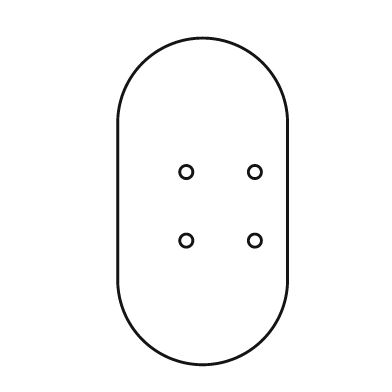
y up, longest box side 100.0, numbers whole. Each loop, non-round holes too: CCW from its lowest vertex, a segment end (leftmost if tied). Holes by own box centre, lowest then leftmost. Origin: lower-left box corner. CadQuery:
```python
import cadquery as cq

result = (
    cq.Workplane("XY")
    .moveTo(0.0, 26.0)
    .threePointArc((26.0, 0.0), (52.0, 26.0))
    .lineTo(52.0, 74.0)
    .threePointArc((26.0, 100.0), (0.0, 74.0))
    .close()
    .moveTo(21.0, 38.0)
    .circle(2.0)
    .moveTo(42.0, 38.0)
    .circle(2.0)
    .moveTo(21.0, 59.0)
    .circle(2.0)
    .moveTo(42.0, 59.0)
    .circle(2.0)
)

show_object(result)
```